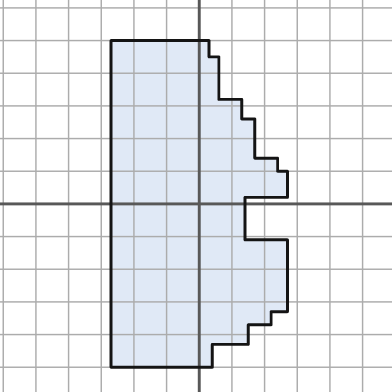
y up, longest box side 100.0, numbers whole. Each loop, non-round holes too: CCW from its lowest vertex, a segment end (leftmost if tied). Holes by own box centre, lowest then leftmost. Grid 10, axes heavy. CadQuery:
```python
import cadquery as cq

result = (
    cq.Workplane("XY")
    .moveTo(-27.0, -50.0)
    .lineTo(4.0, -50.0)
    .lineTo(4.0, -43.0)
    .lineTo(15.0, -43.0)
    .lineTo(15.0, -37.0)
    .lineTo(22.0, -37.0)
    .lineTo(22.0, -33.0)
    .lineTo(27.0, -33.0)
    .lineTo(27.0, -11.0)
    .lineTo(14.0, -11.0)
    .lineTo(14.0, 2.0)
    .lineTo(27.0, 2.0)
    .lineTo(27.0, 10.0)
    .lineTo(24.0, 10.0)
    .lineTo(24.0, 14.0)
    .lineTo(17.0, 14.0)
    .lineTo(17.0, 26.0)
    .lineTo(13.0, 26.0)
    .lineTo(13.0, 32.0)
    .lineTo(6.0, 32.0)
    .lineTo(6.0, 45.0)
    .lineTo(3.0, 45.0)
    .lineTo(3.0, 50.0)
    .lineTo(-27.0, 50.0)
    .close()
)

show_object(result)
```